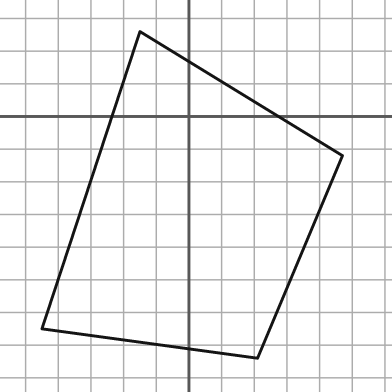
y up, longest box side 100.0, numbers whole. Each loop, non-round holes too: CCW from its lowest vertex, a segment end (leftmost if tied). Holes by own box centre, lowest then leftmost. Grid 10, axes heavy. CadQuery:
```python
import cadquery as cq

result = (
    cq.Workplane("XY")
    .moveTo(21.0, -74.0)
    .lineTo(47.0, -12.0)
    .lineTo(-15.0, 26.0)
    .lineTo(-45.0, -65.0)
    .close()
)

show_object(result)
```